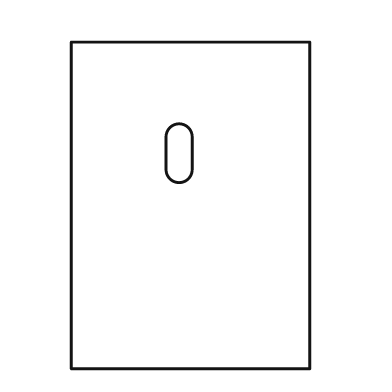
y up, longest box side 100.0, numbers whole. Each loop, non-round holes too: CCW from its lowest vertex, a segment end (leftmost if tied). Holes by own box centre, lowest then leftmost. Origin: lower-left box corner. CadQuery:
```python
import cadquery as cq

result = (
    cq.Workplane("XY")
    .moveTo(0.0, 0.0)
    .lineTo(73.0, 0.0)
    .lineTo(73.0, 100.0)
    .lineTo(0.0, 100.0)
    .close()
    .moveTo(29.0, 61.0)
    .threePointArc((33.0, 57.0), (37.0, 61.0))
    .lineTo(37.0, 71.0)
    .threePointArc((33.0, 75.0), (29.0, 71.0))
    .close()
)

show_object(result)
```